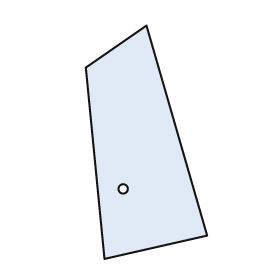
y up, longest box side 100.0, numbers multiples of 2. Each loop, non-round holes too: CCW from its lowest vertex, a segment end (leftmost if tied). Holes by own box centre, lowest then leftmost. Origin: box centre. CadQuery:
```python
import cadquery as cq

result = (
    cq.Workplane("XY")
    .moveTo(-18.0, -50.0)
    .lineTo(26.0, -40.0)
    .lineTo(0.0, 50.0)
    .lineTo(-26.0, 32.0)
    .close()
    .moveTo(-10.0, -20.0)
    .circle(2.0)
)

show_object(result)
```